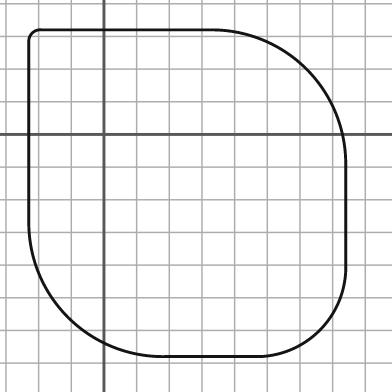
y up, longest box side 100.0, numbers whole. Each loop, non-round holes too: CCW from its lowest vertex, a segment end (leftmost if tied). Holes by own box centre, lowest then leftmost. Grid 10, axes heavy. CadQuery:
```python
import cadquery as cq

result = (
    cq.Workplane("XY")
    .moveTo(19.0, -68.0)
    .lineTo(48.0, -68.0)
    .threePointArc((66.0, -60.0), (74.0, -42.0))
    .lineTo(74.0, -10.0)
    .threePointArc((62.0, 20.0), (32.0, 32.0))
    .lineTo(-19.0, 32.0)
    .threePointArc((-22.0, 31.0), (-23.0, 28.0))
    .lineTo(-23.0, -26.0)
    .threePointArc((-11.0, -56.0), (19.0, -68.0))
    .close()
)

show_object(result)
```